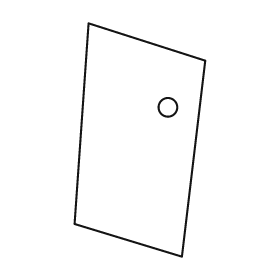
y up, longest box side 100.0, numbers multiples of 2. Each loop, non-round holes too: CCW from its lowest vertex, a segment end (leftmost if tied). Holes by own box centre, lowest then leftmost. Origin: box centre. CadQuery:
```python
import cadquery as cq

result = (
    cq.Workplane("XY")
    .moveTo(18.0, -50.0)
    .lineTo(28.0, 34.0)
    .lineTo(-22.0, 50.0)
    .lineTo(-28.0, -36.0)
    .close()
    .moveTo(12.0, 14.0)
    .circle(4.0)
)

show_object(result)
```